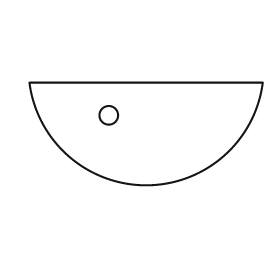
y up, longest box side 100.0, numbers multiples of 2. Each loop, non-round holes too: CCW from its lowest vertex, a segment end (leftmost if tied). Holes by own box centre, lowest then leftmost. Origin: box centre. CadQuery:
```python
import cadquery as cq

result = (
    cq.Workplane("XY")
    .moveTo(-50.0, 22.0)
    .threePointArc((0.0, -22.0), (50.0, 22.0))
    .close()
    .moveTo(-16.0, 8.0)
    .circle(4.0)
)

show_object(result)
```